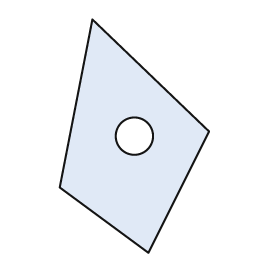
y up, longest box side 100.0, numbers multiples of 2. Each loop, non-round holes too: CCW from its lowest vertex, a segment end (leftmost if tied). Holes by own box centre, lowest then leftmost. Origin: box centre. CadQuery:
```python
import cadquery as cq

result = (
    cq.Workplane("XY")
    .moveTo(6.0, -50.0)
    .lineTo(32.0, 2.0)
    .lineTo(-18.0, 50.0)
    .lineTo(-32.0, -22.0)
    .close()
    .moveTo(0.0, 0.0)
    .circle(8.0)
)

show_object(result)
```